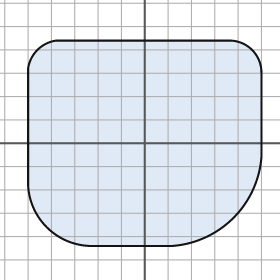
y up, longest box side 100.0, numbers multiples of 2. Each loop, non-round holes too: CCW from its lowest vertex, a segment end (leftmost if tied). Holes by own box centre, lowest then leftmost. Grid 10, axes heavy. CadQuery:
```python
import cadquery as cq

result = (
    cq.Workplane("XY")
    .moveTo(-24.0, -44.0)
    .lineTo(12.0, -44.0)
    .threePointArc((38.0, -32.0), (50.0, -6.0))
    .lineTo(50.0, 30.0)
    .threePointArc((46.0, 40.0), (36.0, 44.0))
    .lineTo(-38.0, 44.0)
    .threePointArc((-46.0, 40.0), (-50.0, 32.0))
    .lineTo(-50.0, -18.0)
    .threePointArc((-42.0, -36.0), (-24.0, -44.0))
    .close()
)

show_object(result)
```